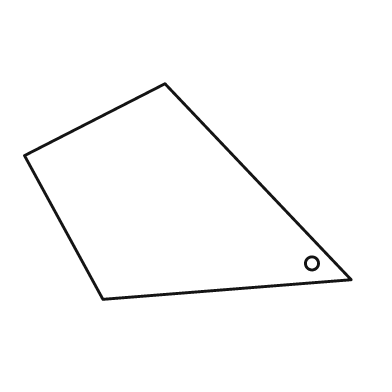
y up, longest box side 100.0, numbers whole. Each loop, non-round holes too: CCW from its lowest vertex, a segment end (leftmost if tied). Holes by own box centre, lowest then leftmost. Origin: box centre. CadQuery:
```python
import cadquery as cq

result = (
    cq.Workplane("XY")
    .moveTo(-26.0, -33.0)
    .lineTo(50.0, -27.0)
    .lineTo(-7.0, 33.0)
    .lineTo(-50.0, 11.0)
    .close()
    .moveTo(38.0, -22.0)
    .circle(2.0)
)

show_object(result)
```